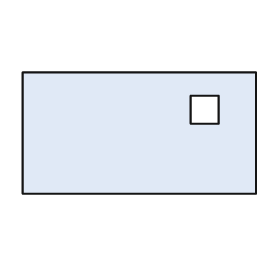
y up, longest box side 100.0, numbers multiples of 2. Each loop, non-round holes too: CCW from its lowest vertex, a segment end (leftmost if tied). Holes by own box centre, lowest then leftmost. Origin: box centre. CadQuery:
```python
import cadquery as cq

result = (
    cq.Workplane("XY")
    .moveTo(-50.0, -26.0)
    .lineTo(50.0, -26.0)
    .lineTo(50.0, 26.0)
    .lineTo(-50.0, 26.0)
    .close()
    .moveTo(22.0, 4.0)
    .lineTo(34.0, 4.0)
    .lineTo(34.0, 16.0)
    .lineTo(22.0, 16.0)
    .close()
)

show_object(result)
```